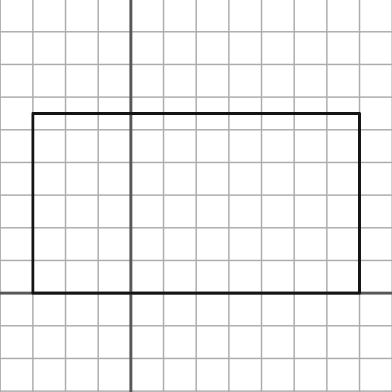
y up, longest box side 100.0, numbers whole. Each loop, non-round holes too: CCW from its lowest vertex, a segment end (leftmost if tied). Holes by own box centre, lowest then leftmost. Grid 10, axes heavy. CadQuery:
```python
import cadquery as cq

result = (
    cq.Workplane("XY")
    .moveTo(-30.0, 0.0)
    .lineTo(70.0, 0.0)
    .lineTo(70.0, 55.0)
    .lineTo(-30.0, 55.0)
    .close()
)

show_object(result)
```